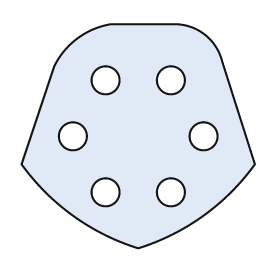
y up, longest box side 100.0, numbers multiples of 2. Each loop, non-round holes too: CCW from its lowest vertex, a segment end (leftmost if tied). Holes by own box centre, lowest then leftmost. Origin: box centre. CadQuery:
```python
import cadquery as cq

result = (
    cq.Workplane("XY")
    .moveTo(0.0, -48.0)
    .threePointArc((28.0, -34.0), (50.0, -12.0))
    .lineTo(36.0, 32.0)
    .threePointArc((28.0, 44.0), (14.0, 48.0))
    .lineTo(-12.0, 48.0)
    .threePointArc((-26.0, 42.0), (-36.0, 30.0))
    .lineTo(-50.0, -12.0)
    .threePointArc((-28.0, -34.0), (0.0, -48.0))
    .close()
    .moveTo(-14.0, -24.0)
    .circle(6.0)
    .moveTo(14.0, -24.0)
    .circle(6.0)
    .moveTo(-28.0, 0.0)
    .circle(6.0)
    .moveTo(28.0, 0.0)
    .circle(6.0)
    .moveTo(-14.0, 24.0)
    .circle(6.0)
    .moveTo(14.0, 24.0)
    .circle(6.0)
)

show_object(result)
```